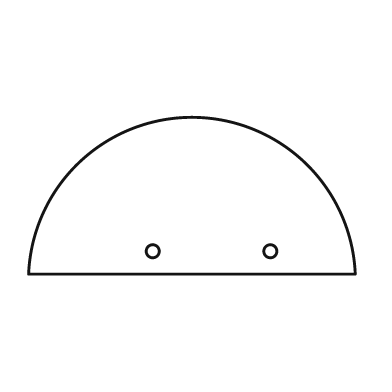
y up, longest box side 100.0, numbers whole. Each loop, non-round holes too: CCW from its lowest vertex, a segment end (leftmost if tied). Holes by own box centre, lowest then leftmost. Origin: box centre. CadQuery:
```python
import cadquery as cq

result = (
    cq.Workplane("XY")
    .moveTo(-50.0, -24.0)
    .lineTo(50.0, -24.0)
    .threePointArc((0.0, 24.0), (-50.0, -24.0))
    .close()
    .moveTo(-12.0, -17.0)
    .circle(2.0)
    .moveTo(24.0, -17.0)
    .circle(2.0)
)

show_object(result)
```